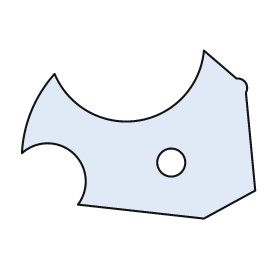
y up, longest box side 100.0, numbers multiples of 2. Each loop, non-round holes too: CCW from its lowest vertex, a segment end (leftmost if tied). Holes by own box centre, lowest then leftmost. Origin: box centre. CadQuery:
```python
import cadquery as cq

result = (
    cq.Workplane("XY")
    .moveTo(28.0, -36.0)
    .lineTo(50.0, -24.0)
    .lineTo(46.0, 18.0)
    .threePointArc((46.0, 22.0), (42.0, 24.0))
    .lineTo(28.0, 36.0)
    .threePointArc((0.0, 6.0), (-36.0, 26.0))
    .threePointArc((-46.0, 10.0), (-50.0, -8.0))
    .threePointArc((-28.0, -8.0), (-26.0, -30.0))
    .close()
    .moveTo(14.0, -12.0)
    .circle(6.0)
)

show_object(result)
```